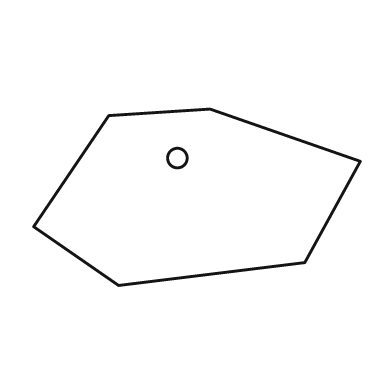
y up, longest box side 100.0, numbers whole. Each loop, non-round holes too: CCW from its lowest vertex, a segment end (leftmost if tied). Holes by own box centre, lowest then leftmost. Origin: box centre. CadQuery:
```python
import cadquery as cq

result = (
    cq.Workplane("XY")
    .moveTo(-24.0, -27.0)
    .lineTo(33.0, -20.0)
    .lineTo(50.0, 11.0)
    .lineTo(4.0, 27.0)
    .lineTo(-27.0, 25.0)
    .lineTo(-50.0, -9.0)
    .close()
    .moveTo(-6.0, 12.0)
    .circle(3.0)
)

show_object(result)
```